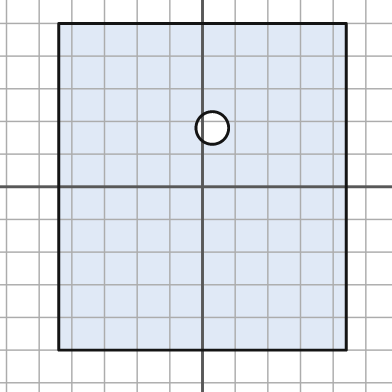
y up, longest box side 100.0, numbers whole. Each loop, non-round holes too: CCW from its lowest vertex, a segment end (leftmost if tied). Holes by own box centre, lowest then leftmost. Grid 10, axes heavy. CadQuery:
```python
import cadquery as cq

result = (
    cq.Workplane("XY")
    .moveTo(-44.0, -50.0)
    .lineTo(44.0, -50.0)
    .lineTo(44.0, 50.0)
    .lineTo(-44.0, 50.0)
    .close()
    .moveTo(3.0, 18.0)
    .circle(5.0)
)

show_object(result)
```